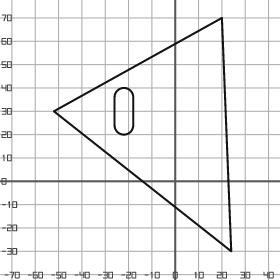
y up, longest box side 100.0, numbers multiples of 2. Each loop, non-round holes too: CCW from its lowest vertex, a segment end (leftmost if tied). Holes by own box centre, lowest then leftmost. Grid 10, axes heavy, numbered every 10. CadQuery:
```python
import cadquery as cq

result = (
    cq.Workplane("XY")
    .moveTo(24.0, -30.0)
    .lineTo(20.0, 70.0)
    .lineTo(-52.0, 30.0)
    .close()
    .moveTo(-26.0, 24.0)
    .threePointArc((-22.0, 20.0), (-18.0, 24.0))
    .lineTo(-18.0, 36.0)
    .threePointArc((-22.0, 40.0), (-26.0, 36.0))
    .close()
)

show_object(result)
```